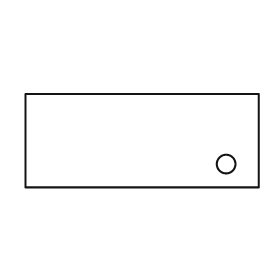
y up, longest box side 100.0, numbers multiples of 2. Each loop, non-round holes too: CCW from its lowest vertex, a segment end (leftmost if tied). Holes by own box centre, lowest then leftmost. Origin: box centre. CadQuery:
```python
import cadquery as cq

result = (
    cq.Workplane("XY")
    .moveTo(-50.0, -20.0)
    .lineTo(50.0, -20.0)
    .lineTo(50.0, 20.0)
    .lineTo(-50.0, 20.0)
    .close()
    .moveTo(36.0, -10.0)
    .circle(4.0)
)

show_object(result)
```